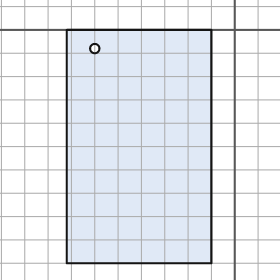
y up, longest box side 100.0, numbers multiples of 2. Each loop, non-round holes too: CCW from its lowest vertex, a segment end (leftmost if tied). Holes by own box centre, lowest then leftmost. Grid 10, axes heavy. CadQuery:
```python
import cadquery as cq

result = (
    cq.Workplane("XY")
    .moveTo(-72.0, -100.0)
    .lineTo(-10.0, -100.0)
    .lineTo(-10.0, 0.0)
    .lineTo(-72.0, 0.0)
    .close()
    .moveTo(-60.0, -8.0)
    .circle(2.0)
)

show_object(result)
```